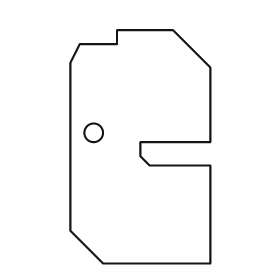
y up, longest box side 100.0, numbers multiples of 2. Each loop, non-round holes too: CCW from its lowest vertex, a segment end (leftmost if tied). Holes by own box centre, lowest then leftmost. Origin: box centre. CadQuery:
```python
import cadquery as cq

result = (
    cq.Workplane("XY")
    .moveTo(-16.0, -50.0)
    .lineTo(30.0, -50.0)
    .lineTo(30.0, -8.0)
    .lineTo(4.0, -8.0)
    .lineTo(0.0, -4.0)
    .lineTo(0.0, 2.0)
    .lineTo(30.0, 2.0)
    .lineTo(30.0, 34.0)
    .lineTo(14.0, 50.0)
    .lineTo(-10.0, 50.0)
    .lineTo(-10.0, 44.0)
    .lineTo(-26.0, 44.0)
    .lineTo(-30.0, 36.0)
    .lineTo(-30.0, -36.0)
    .close()
    .moveTo(-20.0, 6.0)
    .circle(4.0)
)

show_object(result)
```